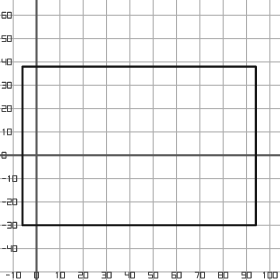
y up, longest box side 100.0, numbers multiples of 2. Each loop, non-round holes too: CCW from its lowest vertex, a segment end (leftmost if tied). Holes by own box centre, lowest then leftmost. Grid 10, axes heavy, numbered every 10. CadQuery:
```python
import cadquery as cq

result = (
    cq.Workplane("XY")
    .moveTo(-6.0, -30.0)
    .lineTo(94.0, -30.0)
    .lineTo(94.0, 38.0)
    .lineTo(-6.0, 38.0)
    .close()
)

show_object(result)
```